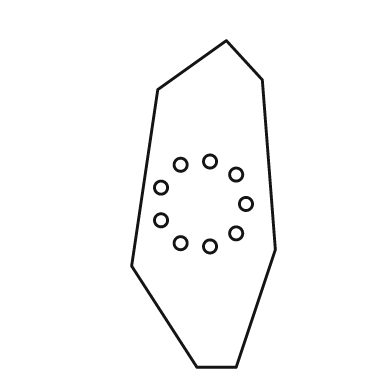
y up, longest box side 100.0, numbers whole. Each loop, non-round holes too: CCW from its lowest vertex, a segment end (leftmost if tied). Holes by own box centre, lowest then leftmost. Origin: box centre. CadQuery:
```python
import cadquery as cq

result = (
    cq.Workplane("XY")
    .moveTo(-2.0, -50.0)
    .lineTo(10.0, -50.0)
    .lineTo(22.0, -14.0)
    .lineTo(18.0, 38.0)
    .lineTo(7.0, 50.0)
    .lineTo(-14.0, 35.0)
    .lineTo(-22.0, -19.0)
    .close()
    .moveTo(2.0, -13.0)
    .circle(2.0)
    .moveTo(-7.0, -12.0)
    .circle(2.0)
    .moveTo(10.0, -9.0)
    .circle(2.0)
    .moveTo(-13.0, -5.0)
    .circle(2.0)
    .moveTo(13.0, 0.0)
    .circle(2.0)
    .moveTo(-13.0, 5.0)
    .circle(2.0)
    .moveTo(10.0, 9.0)
    .circle(2.0)
    .moveTo(-7.0, 12.0)
    .circle(2.0)
    .moveTo(2.0, 13.0)
    .circle(2.0)
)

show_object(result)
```